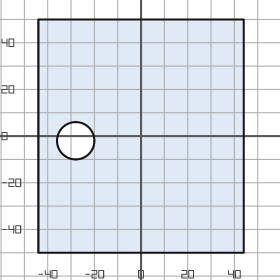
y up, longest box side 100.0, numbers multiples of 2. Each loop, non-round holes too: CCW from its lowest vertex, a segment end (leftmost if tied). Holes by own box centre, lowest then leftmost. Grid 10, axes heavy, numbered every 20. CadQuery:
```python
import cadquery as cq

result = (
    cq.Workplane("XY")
    .moveTo(-44.0, -50.0)
    .lineTo(44.0, -50.0)
    .lineTo(44.0, 50.0)
    .lineTo(-44.0, 50.0)
    .close()
    .moveTo(-28.0, -2.0)
    .circle(8.0)
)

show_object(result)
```